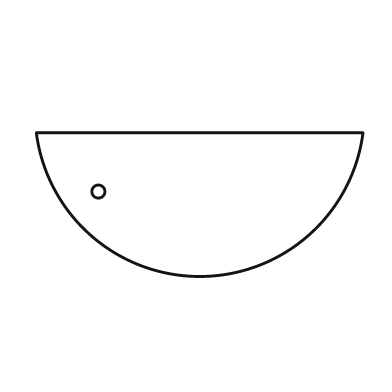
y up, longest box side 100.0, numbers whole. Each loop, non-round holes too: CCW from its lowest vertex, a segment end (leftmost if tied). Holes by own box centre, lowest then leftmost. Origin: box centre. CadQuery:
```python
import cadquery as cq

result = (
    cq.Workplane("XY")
    .moveTo(-50.0, 22.0)
    .threePointArc((0.0, -22.0), (50.0, 22.0))
    .close()
    .moveTo(-31.0, 4.0)
    .circle(2.0)
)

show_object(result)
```